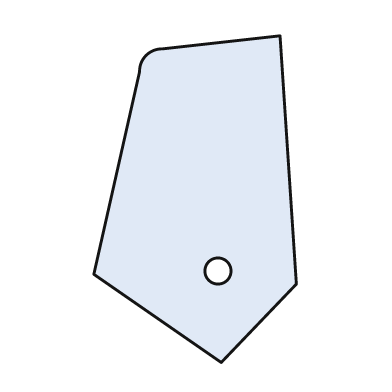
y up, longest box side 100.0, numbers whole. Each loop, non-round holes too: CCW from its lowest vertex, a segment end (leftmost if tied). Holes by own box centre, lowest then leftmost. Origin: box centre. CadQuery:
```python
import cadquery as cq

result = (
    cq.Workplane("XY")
    .moveTo(8.0, -50.0)
    .lineTo(31.0, -26.0)
    .lineTo(26.0, 50.0)
    .lineTo(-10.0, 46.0)
    .threePointArc((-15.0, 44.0), (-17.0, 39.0))
    .lineTo(-31.0, -23.0)
    .close()
    .moveTo(7.0, -22.0)
    .circle(4.0)
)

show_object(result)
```